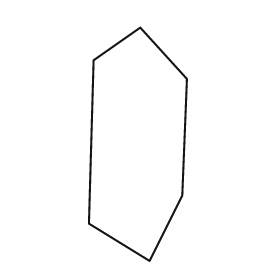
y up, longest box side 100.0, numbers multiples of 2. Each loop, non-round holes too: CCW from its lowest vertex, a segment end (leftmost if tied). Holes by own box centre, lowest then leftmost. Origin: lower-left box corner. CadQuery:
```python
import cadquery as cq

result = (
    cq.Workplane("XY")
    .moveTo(26.0, 0.0)
    .lineTo(40.0, 28.0)
    .lineTo(42.0, 78.0)
    .lineTo(22.0, 100.0)
    .lineTo(2.0, 86.0)
    .lineTo(0.0, 16.0)
    .close()
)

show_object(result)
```